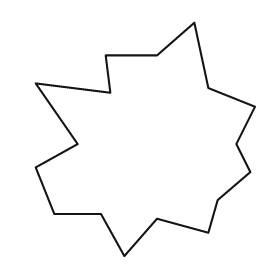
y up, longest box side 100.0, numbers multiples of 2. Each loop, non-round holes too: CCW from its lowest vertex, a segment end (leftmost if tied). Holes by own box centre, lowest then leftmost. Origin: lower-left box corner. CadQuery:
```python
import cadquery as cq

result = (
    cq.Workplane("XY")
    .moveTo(38.0, 0.0)
    .lineTo(52.0, 16.0)
    .lineTo(74.0, 10.0)
    .lineTo(78.0, 24.0)
    .lineTo(92.0, 36.0)
    .lineTo(86.0, 48.0)
    .lineTo(94.0, 64.0)
    .lineTo(74.0, 72.0)
    .lineTo(68.0, 100.0)
    .lineTo(52.0, 86.0)
    .lineTo(30.0, 86.0)
    .lineTo(32.0, 70.0)
    .lineTo(0.0, 74.0)
    .lineTo(18.0, 48.0)
    .lineTo(0.0, 38.0)
    .lineTo(8.0, 18.0)
    .lineTo(28.0, 18.0)
    .close()
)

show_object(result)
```